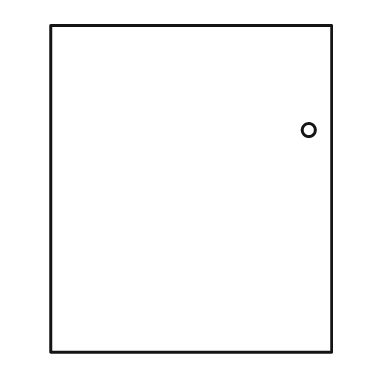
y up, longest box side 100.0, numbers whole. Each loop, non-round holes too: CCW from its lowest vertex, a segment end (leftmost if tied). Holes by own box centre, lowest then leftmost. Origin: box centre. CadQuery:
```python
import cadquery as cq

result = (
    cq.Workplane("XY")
    .moveTo(-43.0, -50.0)
    .lineTo(43.0, -50.0)
    .lineTo(43.0, 50.0)
    .lineTo(-43.0, 50.0)
    .close()
    .moveTo(36.0, 18.0)
    .circle(2.0)
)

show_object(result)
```